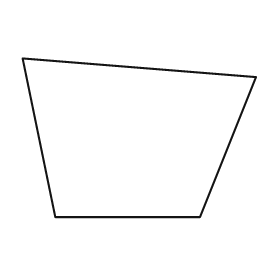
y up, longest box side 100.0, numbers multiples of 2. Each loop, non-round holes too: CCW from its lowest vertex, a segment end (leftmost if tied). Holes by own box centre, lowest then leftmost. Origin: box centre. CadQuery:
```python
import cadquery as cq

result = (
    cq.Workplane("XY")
    .moveTo(-36.0, -34.0)
    .lineTo(26.0, -34.0)
    .lineTo(50.0, 26.0)
    .lineTo(-50.0, 34.0)
    .close()
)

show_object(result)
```